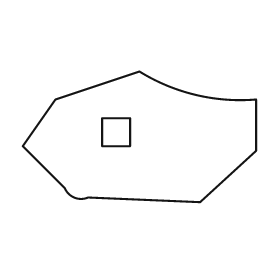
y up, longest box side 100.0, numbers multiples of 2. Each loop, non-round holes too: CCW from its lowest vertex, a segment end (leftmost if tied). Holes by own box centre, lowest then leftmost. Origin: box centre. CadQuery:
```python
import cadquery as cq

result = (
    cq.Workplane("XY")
    .moveTo(26.0, -28.0)
    .lineTo(50.0, -6.0)
    .lineTo(50.0, 16.0)
    .threePointArc((24.0, 18.0), (0.0, 28.0))
    .lineTo(-36.0, 16.0)
    .lineTo(-50.0, -4.0)
    .lineTo(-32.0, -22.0)
    .threePointArc((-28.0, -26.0), (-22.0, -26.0))
    .close()
    .moveTo(-16.0, -4.0)
    .lineTo(-4.0, -4.0)
    .lineTo(-4.0, 8.0)
    .lineTo(-16.0, 8.0)
    .close()
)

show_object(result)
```